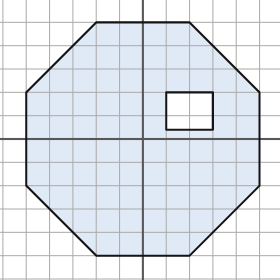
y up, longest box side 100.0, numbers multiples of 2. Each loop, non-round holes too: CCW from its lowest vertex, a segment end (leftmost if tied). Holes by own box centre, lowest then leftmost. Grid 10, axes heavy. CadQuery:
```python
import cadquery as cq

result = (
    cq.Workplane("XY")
    .moveTo(-20.0, -50.0)
    .lineTo(20.0, -50.0)
    .lineTo(50.0, -20.0)
    .lineTo(50.0, 20.0)
    .lineTo(20.0, 50.0)
    .lineTo(-20.0, 50.0)
    .lineTo(-50.0, 20.0)
    .lineTo(-50.0, -20.0)
    .close()
    .moveTo(10.0, 4.0)
    .lineTo(30.0, 4.0)
    .lineTo(30.0, 20.0)
    .lineTo(10.0, 20.0)
    .close()
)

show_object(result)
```